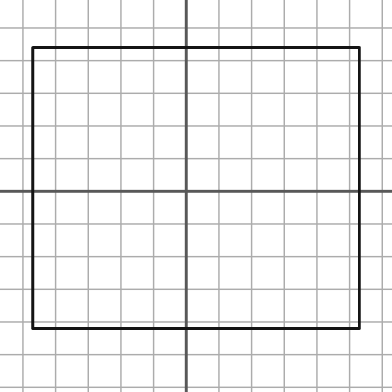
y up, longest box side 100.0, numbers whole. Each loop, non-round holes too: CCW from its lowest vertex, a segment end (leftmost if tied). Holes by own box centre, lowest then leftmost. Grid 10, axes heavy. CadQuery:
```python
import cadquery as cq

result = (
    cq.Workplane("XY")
    .moveTo(-47.0, -42.0)
    .lineTo(53.0, -42.0)
    .lineTo(53.0, 44.0)
    .lineTo(-47.0, 44.0)
    .close()
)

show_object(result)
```